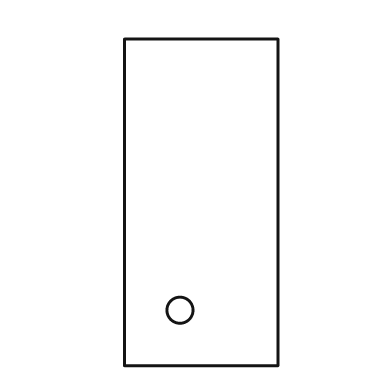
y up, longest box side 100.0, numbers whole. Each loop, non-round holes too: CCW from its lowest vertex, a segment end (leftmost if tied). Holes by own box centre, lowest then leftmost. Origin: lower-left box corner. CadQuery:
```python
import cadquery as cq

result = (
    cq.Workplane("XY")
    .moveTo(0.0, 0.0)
    .lineTo(47.0, 0.0)
    .lineTo(47.0, 100.0)
    .lineTo(0.0, 100.0)
    .close()
    .moveTo(17.0, 17.0)
    .circle(4.0)
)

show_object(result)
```